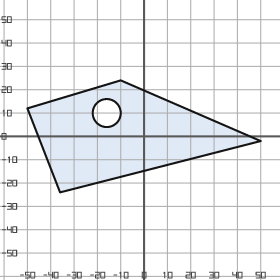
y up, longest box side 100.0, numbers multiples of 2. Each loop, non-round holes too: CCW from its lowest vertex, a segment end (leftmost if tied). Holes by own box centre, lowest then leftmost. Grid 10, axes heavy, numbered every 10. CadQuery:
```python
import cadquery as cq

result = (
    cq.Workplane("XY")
    .moveTo(-36.0, -24.0)
    .lineTo(50.0, -2.0)
    .lineTo(-10.0, 24.0)
    .lineTo(-50.0, 12.0)
    .close()
    .moveTo(-16.0, 10.0)
    .circle(6.0)
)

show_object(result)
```